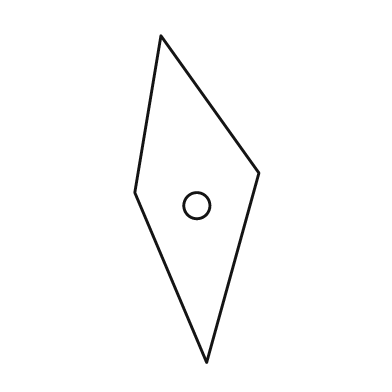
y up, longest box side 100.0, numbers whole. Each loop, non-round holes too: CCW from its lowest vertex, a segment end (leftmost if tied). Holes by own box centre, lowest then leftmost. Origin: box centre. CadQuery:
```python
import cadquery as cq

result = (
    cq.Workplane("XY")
    .moveTo(3.0, -50.0)
    .lineTo(19.0, 8.0)
    .lineTo(-11.0, 50.0)
    .lineTo(-19.0, 2.0)
    .close()
    .moveTo(0.0, -2.0)
    .circle(4.0)
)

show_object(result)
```